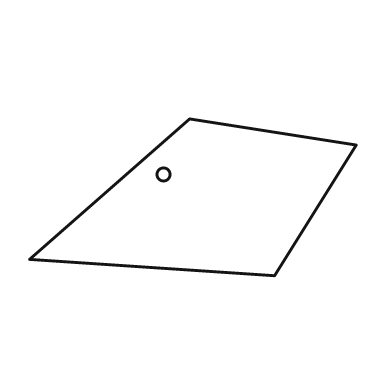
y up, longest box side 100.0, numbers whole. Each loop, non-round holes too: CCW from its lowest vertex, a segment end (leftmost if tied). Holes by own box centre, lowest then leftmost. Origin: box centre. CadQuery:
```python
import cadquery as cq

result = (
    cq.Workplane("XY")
    .moveTo(25.0, -24.0)
    .lineTo(50.0, 16.0)
    .lineTo(-1.0, 24.0)
    .lineTo(-50.0, -19.0)
    .close()
    .moveTo(-9.0, 7.0)
    .circle(2.0)
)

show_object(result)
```